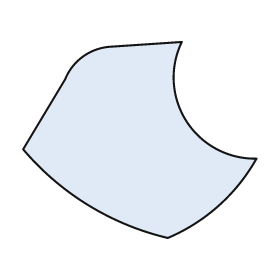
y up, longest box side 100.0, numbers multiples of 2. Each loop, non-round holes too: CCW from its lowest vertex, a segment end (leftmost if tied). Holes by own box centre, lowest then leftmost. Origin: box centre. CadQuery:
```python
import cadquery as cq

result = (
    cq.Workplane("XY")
    .moveTo(12.0, -42.0)
    .threePointArc((34.0, -28.0), (50.0, -8.0))
    .threePointArc((20.0, 8.0), (18.0, 42.0))
    .lineTo(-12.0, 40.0)
    .threePointArc((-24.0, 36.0), (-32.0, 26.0))
    .lineTo(-50.0, -4.0)
    .threePointArc((-22.0, -28.0), (12.0, -42.0))
    .close()
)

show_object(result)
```